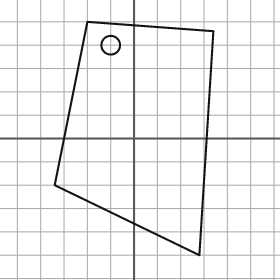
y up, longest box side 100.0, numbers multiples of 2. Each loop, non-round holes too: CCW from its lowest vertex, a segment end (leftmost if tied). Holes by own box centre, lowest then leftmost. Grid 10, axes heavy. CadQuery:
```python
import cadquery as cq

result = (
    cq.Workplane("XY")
    .moveTo(28.0, -50.0)
    .lineTo(34.0, 46.0)
    .lineTo(-20.0, 50.0)
    .lineTo(-34.0, -20.0)
    .close()
    .moveTo(-10.0, 40.0)
    .circle(4.0)
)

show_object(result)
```